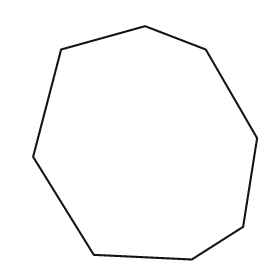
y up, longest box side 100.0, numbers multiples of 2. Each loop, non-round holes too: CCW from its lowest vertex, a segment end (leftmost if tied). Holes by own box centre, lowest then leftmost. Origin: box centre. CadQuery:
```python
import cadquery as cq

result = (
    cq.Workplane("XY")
    .moveTo(20.0, -50.0)
    .lineTo(42.0, -36.0)
    .lineTo(48.0, 2.0)
    .lineTo(26.0, 40.0)
    .lineTo(0.0, 50.0)
    .lineTo(-36.0, 40.0)
    .lineTo(-48.0, -6.0)
    .lineTo(-22.0, -48.0)
    .close()
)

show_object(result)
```